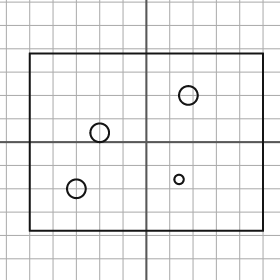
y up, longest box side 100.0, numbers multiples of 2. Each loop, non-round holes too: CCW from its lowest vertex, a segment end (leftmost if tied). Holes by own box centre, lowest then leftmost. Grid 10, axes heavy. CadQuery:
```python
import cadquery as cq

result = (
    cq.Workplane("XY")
    .moveTo(-50.0, -38.0)
    .lineTo(50.0, -38.0)
    .lineTo(50.0, 38.0)
    .lineTo(-50.0, 38.0)
    .close()
    .moveTo(-30.0, -20.0)
    .circle(4.0)
    .moveTo(14.0, -16.0)
    .circle(2.0)
    .moveTo(-20.0, 4.0)
    .circle(4.0)
    .moveTo(18.0, 20.0)
    .circle(4.0)
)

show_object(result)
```